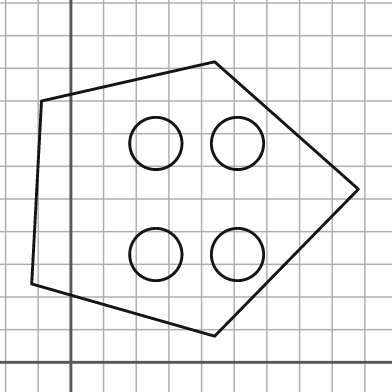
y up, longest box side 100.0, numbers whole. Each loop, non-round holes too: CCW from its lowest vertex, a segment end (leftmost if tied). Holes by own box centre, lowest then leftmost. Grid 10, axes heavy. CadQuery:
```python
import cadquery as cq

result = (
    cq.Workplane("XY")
    .moveTo(44.0, 8.0)
    .lineTo(88.0, 53.0)
    .lineTo(44.0, 92.0)
    .lineTo(-9.0, 80.0)
    .lineTo(-12.0, 24.0)
    .close()
    .moveTo(26.0, 33.0)
    .circle(8.0)
    .moveTo(51.0, 33.0)
    .circle(8.0)
    .moveTo(26.0, 67.0)
    .circle(8.0)
    .moveTo(51.0, 67.0)
    .circle(8.0)
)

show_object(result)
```